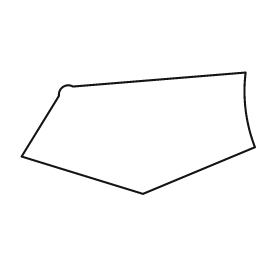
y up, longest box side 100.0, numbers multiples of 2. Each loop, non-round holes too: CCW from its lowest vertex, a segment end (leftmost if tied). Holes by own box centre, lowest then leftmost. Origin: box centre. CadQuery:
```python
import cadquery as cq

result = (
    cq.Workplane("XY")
    .moveTo(2.0, -26.0)
    .lineTo(50.0, -6.0)
    .threePointArc((46.0, 10.0), (46.0, 26.0))
    .lineTo(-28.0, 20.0)
    .threePointArc((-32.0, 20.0), (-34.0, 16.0))
    .lineTo(-50.0, -10.0)
    .close()
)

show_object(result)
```